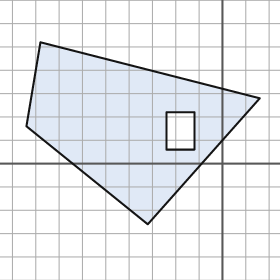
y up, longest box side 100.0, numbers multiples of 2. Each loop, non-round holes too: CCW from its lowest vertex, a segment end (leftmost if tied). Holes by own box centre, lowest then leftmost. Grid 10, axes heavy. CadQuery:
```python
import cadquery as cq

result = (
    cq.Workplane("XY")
    .moveTo(-32.0, -26.0)
    .lineTo(16.0, 28.0)
    .lineTo(-78.0, 52.0)
    .lineTo(-84.0, 16.0)
    .close()
    .moveTo(-24.0, 6.0)
    .lineTo(-12.0, 6.0)
    .lineTo(-12.0, 22.0)
    .lineTo(-24.0, 22.0)
    .close()
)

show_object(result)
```